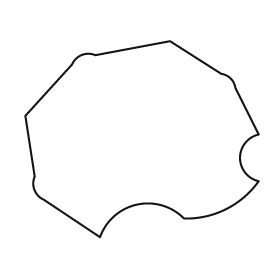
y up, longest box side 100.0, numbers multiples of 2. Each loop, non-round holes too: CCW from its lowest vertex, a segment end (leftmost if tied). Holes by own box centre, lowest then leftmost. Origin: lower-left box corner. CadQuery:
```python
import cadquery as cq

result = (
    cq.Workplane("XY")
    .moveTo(32.0, 0.0)
    .threePointArc((48.0, 14.0), (68.0, 8.0))
    .threePointArc((86.0, 12.0), (100.0, 24.0))
    .threePointArc((92.0, 34.0), (100.0, 44.0))
    .lineTo(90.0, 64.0)
    .threePointArc((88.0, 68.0), (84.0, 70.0))
    .lineTo(62.0, 84.0)
    .lineTo(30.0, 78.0)
    .threePointArc((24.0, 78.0), (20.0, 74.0))
    .lineTo(0.0, 52.0)
    .lineTo(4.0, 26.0)
    .threePointArc((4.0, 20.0), (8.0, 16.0))
    .close()
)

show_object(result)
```